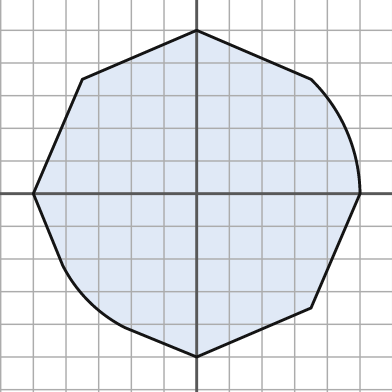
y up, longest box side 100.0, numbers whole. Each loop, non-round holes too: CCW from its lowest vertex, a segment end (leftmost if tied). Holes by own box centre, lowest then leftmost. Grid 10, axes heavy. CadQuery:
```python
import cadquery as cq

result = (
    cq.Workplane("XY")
    .moveTo(0.0, -50.0)
    .lineTo(35.0, -35.0)
    .lineTo(50.0, 0.0)
    .threePointArc((46.0, 19.0), (35.0, 35.0))
    .lineTo(0.0, 50.0)
    .lineTo(-35.0, 35.0)
    .lineTo(-50.0, 0.0)
    .lineTo(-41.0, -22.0)
    .threePointArc((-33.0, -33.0), (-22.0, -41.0))
    .close()
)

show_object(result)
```